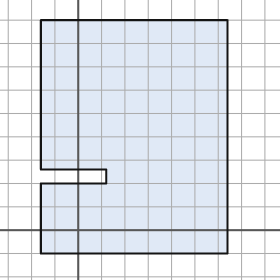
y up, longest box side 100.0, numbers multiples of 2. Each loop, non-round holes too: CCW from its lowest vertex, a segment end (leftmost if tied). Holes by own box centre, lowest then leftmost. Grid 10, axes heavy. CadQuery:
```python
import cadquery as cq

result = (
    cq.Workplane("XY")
    .moveTo(-16.0, -10.0)
    .lineTo(64.0, -10.0)
    .lineTo(64.0, 90.0)
    .lineTo(-16.0, 90.0)
    .lineTo(-16.0, 26.0)
    .lineTo(12.0, 26.0)
    .lineTo(12.0, 20.0)
    .lineTo(-16.0, 20.0)
    .close()
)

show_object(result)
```